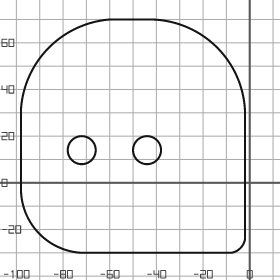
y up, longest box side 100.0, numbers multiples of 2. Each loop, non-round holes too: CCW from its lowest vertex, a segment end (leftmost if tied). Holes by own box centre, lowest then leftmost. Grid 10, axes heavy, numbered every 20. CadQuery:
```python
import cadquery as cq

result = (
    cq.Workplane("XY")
    .moveTo(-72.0, -30.0)
    .lineTo(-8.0, -30.0)
    .threePointArc((-4.0, -28.0), (-2.0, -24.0))
    .lineTo(-2.0, 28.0)
    .threePointArc((-14.0, 58.0), (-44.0, 70.0))
    .lineTo(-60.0, 70.0)
    .threePointArc((-86.0, 58.0), (-98.0, 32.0))
    .lineTo(-98.0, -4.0)
    .threePointArc((-90.0, -22.0), (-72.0, -30.0))
    .close()
    .moveTo(-72.0, 14.0)
    .circle(6.0)
    .moveTo(-44.0, 14.0)
    .circle(6.0)
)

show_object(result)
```